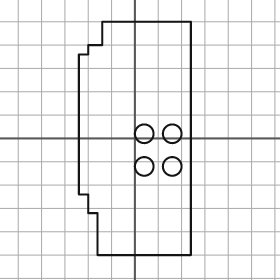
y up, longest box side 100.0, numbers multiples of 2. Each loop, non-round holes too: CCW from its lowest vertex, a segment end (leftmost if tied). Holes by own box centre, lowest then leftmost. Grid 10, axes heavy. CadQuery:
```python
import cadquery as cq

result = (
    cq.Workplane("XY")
    .moveTo(-16.0, -50.0)
    .lineTo(24.0, -50.0)
    .lineTo(24.0, 50.0)
    .lineTo(-14.0, 50.0)
    .lineTo(-14.0, 40.0)
    .lineTo(-20.0, 40.0)
    .lineTo(-20.0, 36.0)
    .lineTo(-24.0, 36.0)
    .lineTo(-24.0, -24.0)
    .lineTo(-20.0, -24.0)
    .lineTo(-20.0, -32.0)
    .lineTo(-16.0, -32.0)
    .close()
    .moveTo(4.0, -12.0)
    .circle(4.0)
    .moveTo(16.0, -12.0)
    .circle(4.0)
    .moveTo(4.0, 2.0)
    .circle(4.0)
    .moveTo(16.0, 2.0)
    .circle(4.0)
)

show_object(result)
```